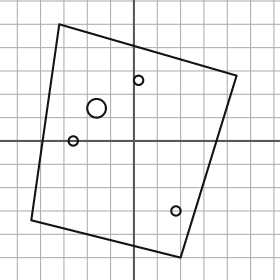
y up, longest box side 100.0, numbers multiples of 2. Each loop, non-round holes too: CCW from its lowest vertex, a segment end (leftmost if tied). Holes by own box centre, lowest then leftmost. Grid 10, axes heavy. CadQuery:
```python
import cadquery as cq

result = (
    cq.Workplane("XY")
    .moveTo(20.0, -50.0)
    .lineTo(44.0, 28.0)
    .lineTo(-32.0, 50.0)
    .lineTo(-44.0, -34.0)
    .close()
    .moveTo(18.0, -30.0)
    .circle(2.0)
    .moveTo(-26.0, 0.0)
    .circle(2.0)
    .moveTo(-16.0, 14.0)
    .circle(4.0)
    .moveTo(2.0, 26.0)
    .circle(2.0)
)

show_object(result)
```